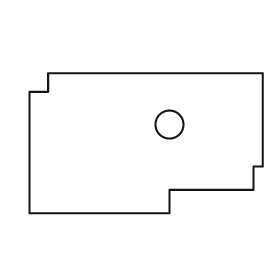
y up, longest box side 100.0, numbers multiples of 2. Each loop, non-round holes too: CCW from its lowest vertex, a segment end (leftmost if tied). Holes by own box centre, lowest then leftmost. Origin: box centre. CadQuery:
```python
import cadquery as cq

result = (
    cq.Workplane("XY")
    .moveTo(-50.0, -30.0)
    .lineTo(10.0, -30.0)
    .lineTo(10.0, -20.0)
    .lineTo(46.0, -20.0)
    .lineTo(46.0, -10.0)
    .lineTo(50.0, -10.0)
    .lineTo(50.0, 30.0)
    .lineTo(-42.0, 30.0)
    .lineTo(-42.0, 22.0)
    .lineTo(-50.0, 22.0)
    .close()
    .moveTo(10.0, 8.0)
    .circle(6.0)
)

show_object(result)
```